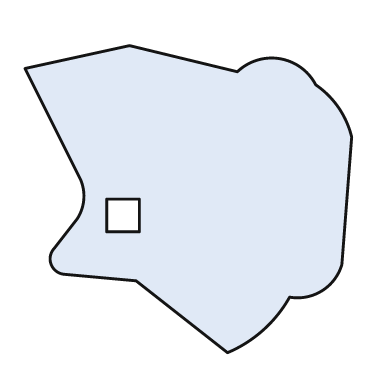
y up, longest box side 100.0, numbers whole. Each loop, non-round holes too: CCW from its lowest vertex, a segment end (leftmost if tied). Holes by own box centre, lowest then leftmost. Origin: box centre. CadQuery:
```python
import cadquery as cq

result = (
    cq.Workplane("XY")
    .moveTo(12.0, -47.0)
    .threePointArc((23.0, -40.0), (31.0, -30.0))
    .threePointArc((41.0, -28.0), (47.0, -20.0))
    .lineTo(50.0, 19.0)
    .threePointArc((46.0, 28.0), (39.0, 35.0))
    .threePointArc((28.0, 43.0), (15.0, 39.0))
    .lineTo(-18.0, 47.0)
    .lineTo(-50.0, 40.0)
    .lineTo(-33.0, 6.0)
    .threePointArc((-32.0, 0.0), (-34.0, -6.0))
    .lineTo(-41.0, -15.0)
    .threePointArc((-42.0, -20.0), (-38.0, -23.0))
    .lineTo(-16.0, -25.0)
    .close()
    .moveTo(-25.0, -10.0)
    .lineTo(-15.0, -10.0)
    .lineTo(-15.0, 0.0)
    .lineTo(-25.0, 0.0)
    .close()
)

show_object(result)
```